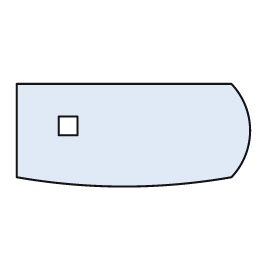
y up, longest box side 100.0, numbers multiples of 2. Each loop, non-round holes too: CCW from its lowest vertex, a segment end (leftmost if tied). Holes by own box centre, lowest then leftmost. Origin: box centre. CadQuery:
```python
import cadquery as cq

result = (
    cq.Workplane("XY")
    .moveTo(-50.0, -18.0)
    .threePointArc((-4.0, -22.0), (42.0, -18.0))
    .threePointArc((50.0, 2.0), (42.0, 22.0))
    .lineTo(-50.0, 22.0)
    .close()
    .moveTo(-32.0, 0.0)
    .lineTo(-24.0, 0.0)
    .lineTo(-24.0, 8.0)
    .lineTo(-32.0, 8.0)
    .close()
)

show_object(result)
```